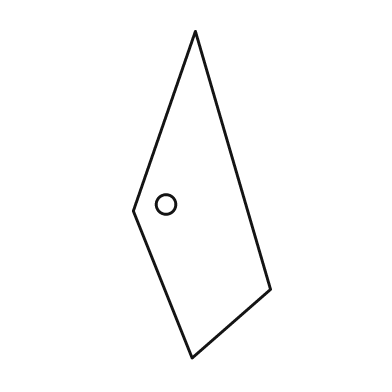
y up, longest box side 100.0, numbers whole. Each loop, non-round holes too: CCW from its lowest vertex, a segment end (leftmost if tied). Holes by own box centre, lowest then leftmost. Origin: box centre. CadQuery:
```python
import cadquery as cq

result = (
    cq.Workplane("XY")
    .moveTo(-3.0, -50.0)
    .lineTo(21.0, -29.0)
    .lineTo(-2.0, 50.0)
    .lineTo(-21.0, -5.0)
    .close()
    .moveTo(-11.0, -3.0)
    .circle(3.0)
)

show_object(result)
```